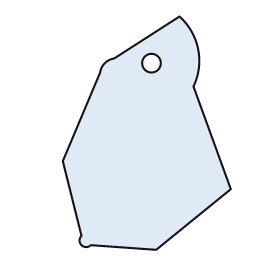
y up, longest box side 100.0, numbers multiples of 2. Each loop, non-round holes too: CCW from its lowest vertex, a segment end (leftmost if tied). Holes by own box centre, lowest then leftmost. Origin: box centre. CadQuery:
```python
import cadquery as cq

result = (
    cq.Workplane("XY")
    .moveTo(4.0, -50.0)
    .lineTo(36.0, -24.0)
    .lineTo(20.0, 20.0)
    .threePointArc((22.0, 36.0), (14.0, 50.0))
    .lineTo(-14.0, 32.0)
    .threePointArc((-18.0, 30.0), (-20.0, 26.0))
    .lineTo(-36.0, -12.0)
    .lineTo(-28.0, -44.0)
    .threePointArc((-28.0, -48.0), (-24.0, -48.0))
    .close()
    .moveTo(2.0, 30.0)
    .circle(4.0)
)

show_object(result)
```